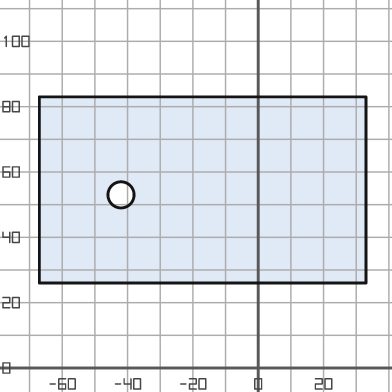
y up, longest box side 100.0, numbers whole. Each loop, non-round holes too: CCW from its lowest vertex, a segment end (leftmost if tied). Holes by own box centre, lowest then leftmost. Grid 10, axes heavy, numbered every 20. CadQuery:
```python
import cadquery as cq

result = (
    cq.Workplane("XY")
    .moveTo(-67.0, 26.0)
    .lineTo(33.0, 26.0)
    .lineTo(33.0, 83.0)
    .lineTo(-67.0, 83.0)
    .close()
    .moveTo(-42.0, 53.0)
    .circle(4.0)
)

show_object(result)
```